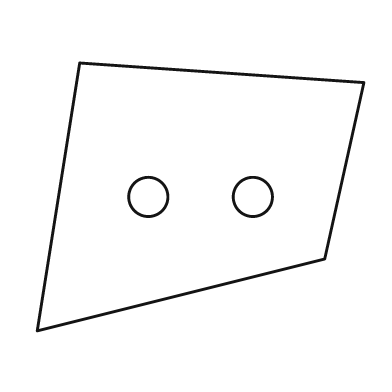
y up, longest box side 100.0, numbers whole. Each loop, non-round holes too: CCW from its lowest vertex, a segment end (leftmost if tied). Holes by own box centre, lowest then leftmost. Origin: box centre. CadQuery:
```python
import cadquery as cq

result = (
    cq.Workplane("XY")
    .moveTo(-50.0, -41.0)
    .lineTo(38.0, -19.0)
    .lineTo(50.0, 35.0)
    .lineTo(-37.0, 41.0)
    .close()
    .moveTo(-16.0, 0.0)
    .circle(6.0)
    .moveTo(16.0, 0.0)
    .circle(6.0)
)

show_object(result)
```